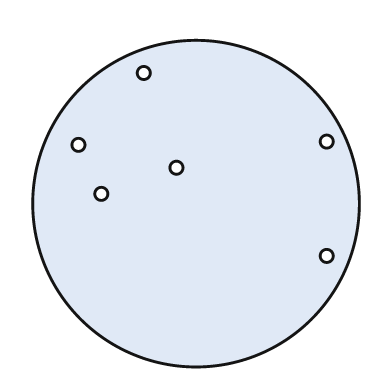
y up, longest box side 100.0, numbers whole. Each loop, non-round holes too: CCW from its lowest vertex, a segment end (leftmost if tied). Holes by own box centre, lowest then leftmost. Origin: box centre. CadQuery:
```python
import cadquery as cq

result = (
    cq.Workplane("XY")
    .moveTo(0.0, 0.0)
    .circle(50.0)
    .moveTo(40.0, -16.0)
    .circle(2.0)
    .moveTo(-29.0, 3.0)
    .circle(2.0)
    .moveTo(-6.0, 11.0)
    .circle(2.0)
    .moveTo(-36.0, 18.0)
    .circle(2.0)
    .moveTo(40.0, 19.0)
    .circle(2.0)
    .moveTo(-16.0, 40.0)
    .circle(2.0)
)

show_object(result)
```